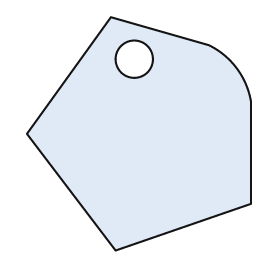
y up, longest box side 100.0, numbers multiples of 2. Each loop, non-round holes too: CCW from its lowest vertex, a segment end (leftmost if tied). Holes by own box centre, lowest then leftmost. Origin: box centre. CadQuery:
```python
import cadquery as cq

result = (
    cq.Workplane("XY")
    .moveTo(-10.0, -50.0)
    .lineTo(48.0, -30.0)
    .lineTo(48.0, 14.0)
    .threePointArc((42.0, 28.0), (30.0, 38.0))
    .lineTo(-12.0, 50.0)
    .lineTo(-48.0, 0.0)
    .close()
    .moveTo(-2.0, 32.0)
    .circle(8.0)
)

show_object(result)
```